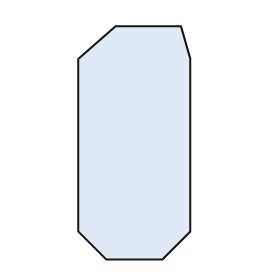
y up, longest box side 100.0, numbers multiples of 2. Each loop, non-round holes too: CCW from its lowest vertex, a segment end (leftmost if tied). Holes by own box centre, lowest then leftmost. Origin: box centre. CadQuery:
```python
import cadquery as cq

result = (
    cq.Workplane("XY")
    .moveTo(-12.0, -50.0)
    .lineTo(12.0, -50.0)
    .lineTo(24.0, -38.0)
    .lineTo(24.0, 36.0)
    .lineTo(20.0, 50.0)
    .lineTo(-8.0, 50.0)
    .lineTo(-24.0, 36.0)
    .lineTo(-24.0, -38.0)
    .close()
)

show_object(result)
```